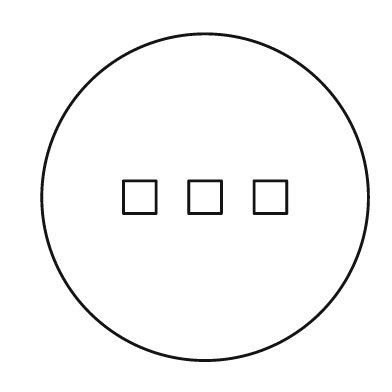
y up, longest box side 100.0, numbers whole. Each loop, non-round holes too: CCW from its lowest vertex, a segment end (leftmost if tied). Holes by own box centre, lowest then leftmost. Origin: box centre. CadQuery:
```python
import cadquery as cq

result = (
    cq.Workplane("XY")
    .moveTo(0.0, 0.0)
    .circle(50.0)
    .moveTo(-25.0, -5.0)
    .lineTo(-15.0, -5.0)
    .lineTo(-15.0, 5.0)
    .lineTo(-25.0, 5.0)
    .close()
    .moveTo(-5.0, -5.0)
    .lineTo(5.0, -5.0)
    .lineTo(5.0, 5.0)
    .lineTo(-5.0, 5.0)
    .close()
    .moveTo(15.0, -5.0)
    .lineTo(25.0, -5.0)
    .lineTo(25.0, 5.0)
    .lineTo(15.0, 5.0)
    .close()
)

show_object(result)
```